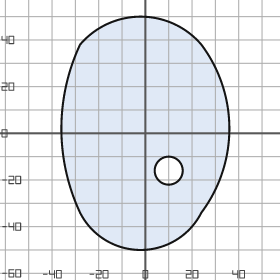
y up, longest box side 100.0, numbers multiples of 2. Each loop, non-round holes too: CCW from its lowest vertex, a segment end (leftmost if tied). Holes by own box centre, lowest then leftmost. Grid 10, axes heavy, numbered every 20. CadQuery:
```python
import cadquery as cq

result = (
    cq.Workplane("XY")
    .moveTo(-28.0, -34.0)
    .threePointArc((-2.0, -50.0), (24.0, -34.0))
    .threePointArc((36.0, 2.0), (24.0, 38.0))
    .threePointArc((-2.0, 50.0), (-28.0, 38.0))
    .threePointArc((-36.0, 2.0), (-28.0, -34.0))
    .close()
    .moveTo(10.0, -16.0)
    .circle(6.0)
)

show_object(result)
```